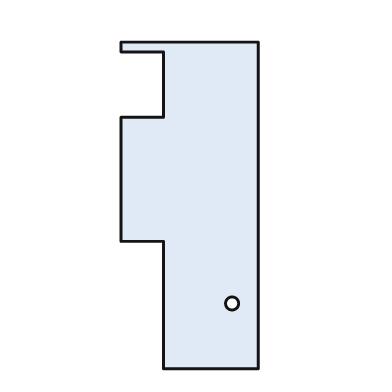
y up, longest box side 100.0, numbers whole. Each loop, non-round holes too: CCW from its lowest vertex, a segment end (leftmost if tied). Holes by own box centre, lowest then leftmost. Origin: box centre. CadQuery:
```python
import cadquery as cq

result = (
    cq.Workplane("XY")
    .moveTo(-8.0, -50.0)
    .lineTo(21.0, -50.0)
    .lineTo(21.0, 50.0)
    .lineTo(-21.0, 50.0)
    .lineTo(-21.0, 47.0)
    .lineTo(-8.0, 47.0)
    .lineTo(-8.0, 27.0)
    .lineTo(-21.0, 27.0)
    .lineTo(-21.0, -11.0)
    .lineTo(-8.0, -11.0)
    .close()
    .moveTo(13.0, -30.0)
    .circle(2.0)
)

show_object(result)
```